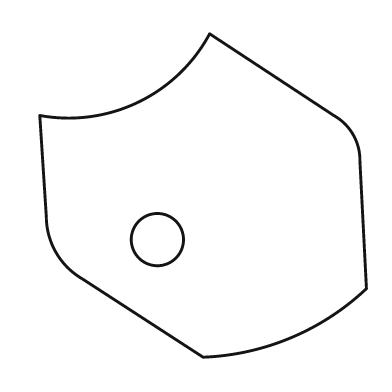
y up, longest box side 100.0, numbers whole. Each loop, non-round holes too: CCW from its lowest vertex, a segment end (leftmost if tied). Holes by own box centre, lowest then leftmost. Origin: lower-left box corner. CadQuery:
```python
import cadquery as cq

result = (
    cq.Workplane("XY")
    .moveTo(50.0, 0.0)
    .threePointArc((77.0, 6.0), (100.0, 21.0))
    .lineTo(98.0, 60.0)
    .threePointArc((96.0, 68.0), (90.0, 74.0))
    .lineTo(52.0, 99.0)
    .threePointArc((30.0, 78.0), (0.0, 74.0))
    .lineTo(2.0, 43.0)
    .threePointArc((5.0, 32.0), (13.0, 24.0))
    .close()
    .moveTo(36.0, 36.0)
    .circle(8.0)
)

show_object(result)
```